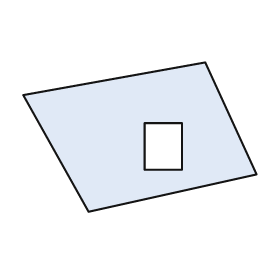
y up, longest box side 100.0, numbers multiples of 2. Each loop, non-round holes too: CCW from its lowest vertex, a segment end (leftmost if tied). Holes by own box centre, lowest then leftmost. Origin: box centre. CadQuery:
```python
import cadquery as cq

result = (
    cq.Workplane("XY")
    .moveTo(-22.0, -32.0)
    .lineTo(50.0, -16.0)
    .lineTo(28.0, 32.0)
    .lineTo(-50.0, 18.0)
    .close()
    .moveTo(2.0, -14.0)
    .lineTo(18.0, -14.0)
    .lineTo(18.0, 6.0)
    .lineTo(2.0, 6.0)
    .close()
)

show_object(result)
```